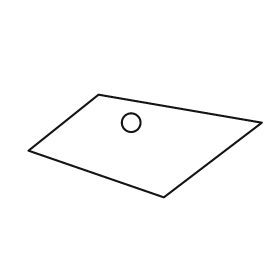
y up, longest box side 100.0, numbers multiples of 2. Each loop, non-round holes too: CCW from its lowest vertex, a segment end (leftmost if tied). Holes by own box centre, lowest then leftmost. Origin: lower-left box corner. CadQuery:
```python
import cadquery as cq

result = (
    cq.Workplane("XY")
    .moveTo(58.0, 0.0)
    .lineTo(100.0, 32.0)
    .lineTo(30.0, 44.0)
    .lineTo(0.0, 20.0)
    .close()
    .moveTo(44.0, 32.0)
    .circle(4.0)
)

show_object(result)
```